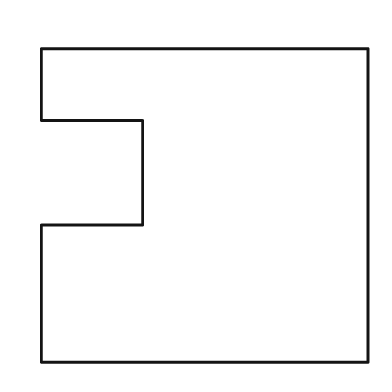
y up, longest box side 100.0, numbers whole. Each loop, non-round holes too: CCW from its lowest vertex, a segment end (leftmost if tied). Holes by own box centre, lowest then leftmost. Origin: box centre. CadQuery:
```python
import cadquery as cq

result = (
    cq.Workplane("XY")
    .moveTo(-50.0, -48.0)
    .lineTo(50.0, -48.0)
    .lineTo(50.0, 48.0)
    .lineTo(-50.0, 48.0)
    .lineTo(-50.0, 26.0)
    .lineTo(-19.0, 26.0)
    .lineTo(-19.0, -6.0)
    .lineTo(-50.0, -6.0)
    .close()
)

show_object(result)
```